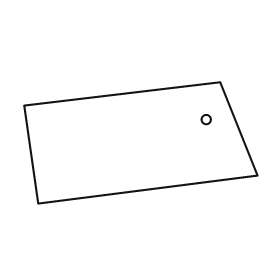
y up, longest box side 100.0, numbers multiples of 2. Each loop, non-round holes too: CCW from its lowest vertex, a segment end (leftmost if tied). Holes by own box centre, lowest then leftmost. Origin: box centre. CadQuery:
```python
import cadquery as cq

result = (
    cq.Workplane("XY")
    .moveTo(-44.0, -26.0)
    .lineTo(50.0, -14.0)
    .lineTo(34.0, 26.0)
    .lineTo(-50.0, 16.0)
    .close()
    .moveTo(28.0, 10.0)
    .circle(2.0)
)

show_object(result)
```